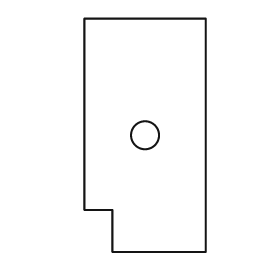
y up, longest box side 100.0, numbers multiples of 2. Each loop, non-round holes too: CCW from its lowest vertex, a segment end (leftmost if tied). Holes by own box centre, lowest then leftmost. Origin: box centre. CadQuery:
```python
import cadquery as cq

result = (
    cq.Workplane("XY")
    .moveTo(-14.0, -50.0)
    .lineTo(26.0, -50.0)
    .lineTo(26.0, 50.0)
    .lineTo(-26.0, 50.0)
    .lineTo(-26.0, -32.0)
    .lineTo(-14.0, -32.0)
    .close()
    .moveTo(0.0, 0.0)
    .circle(6.0)
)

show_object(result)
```